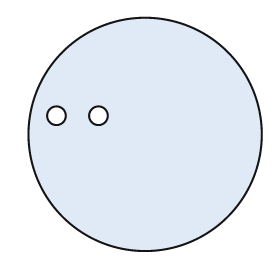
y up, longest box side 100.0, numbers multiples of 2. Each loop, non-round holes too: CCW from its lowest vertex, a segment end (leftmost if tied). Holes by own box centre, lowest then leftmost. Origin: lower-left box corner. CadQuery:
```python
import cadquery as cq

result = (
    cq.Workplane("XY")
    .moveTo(50.0, 50.0)
    .circle(50.0)
    .moveTo(12.0, 58.0)
    .circle(4.0)
    .moveTo(30.0, 58.0)
    .circle(4.0)
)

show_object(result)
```